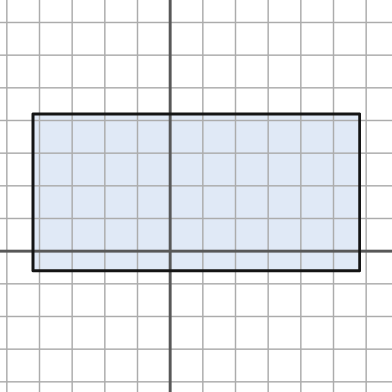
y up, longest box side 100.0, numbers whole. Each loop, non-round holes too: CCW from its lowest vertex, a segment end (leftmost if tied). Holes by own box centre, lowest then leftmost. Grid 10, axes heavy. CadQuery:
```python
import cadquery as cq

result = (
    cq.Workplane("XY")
    .moveTo(-42.0, -6.0)
    .lineTo(58.0, -6.0)
    .lineTo(58.0, 42.0)
    .lineTo(-42.0, 42.0)
    .close()
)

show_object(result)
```